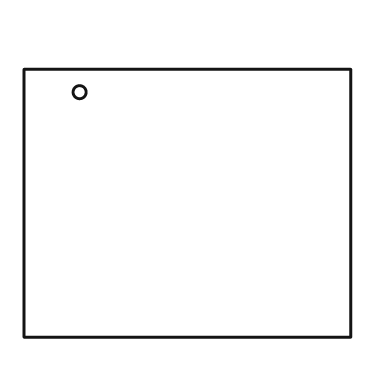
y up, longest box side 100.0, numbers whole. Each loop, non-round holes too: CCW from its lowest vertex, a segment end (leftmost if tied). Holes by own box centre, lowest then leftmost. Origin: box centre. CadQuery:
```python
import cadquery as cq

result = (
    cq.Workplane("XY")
    .moveTo(-50.0, -41.0)
    .lineTo(50.0, -41.0)
    .lineTo(50.0, 41.0)
    .lineTo(-50.0, 41.0)
    .close()
    .moveTo(-33.0, 34.0)
    .circle(2.0)
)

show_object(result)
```